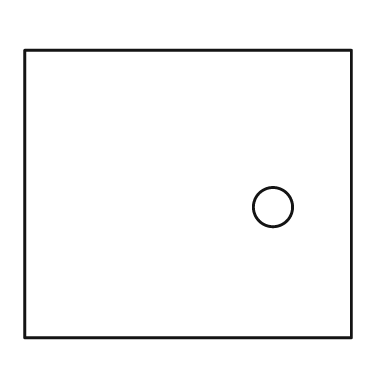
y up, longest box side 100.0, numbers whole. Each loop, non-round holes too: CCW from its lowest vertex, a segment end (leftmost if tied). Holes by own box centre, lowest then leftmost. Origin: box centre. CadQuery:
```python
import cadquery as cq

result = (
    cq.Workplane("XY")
    .moveTo(-50.0, -44.0)
    .lineTo(50.0, -44.0)
    .lineTo(50.0, 44.0)
    .lineTo(-50.0, 44.0)
    .close()
    .moveTo(26.0, -4.0)
    .circle(6.0)
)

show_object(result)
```